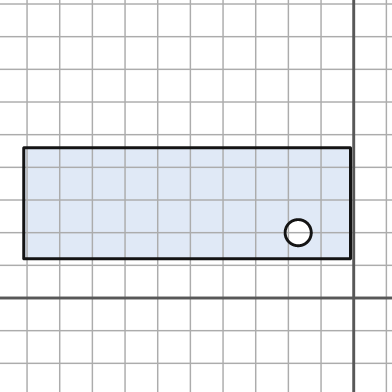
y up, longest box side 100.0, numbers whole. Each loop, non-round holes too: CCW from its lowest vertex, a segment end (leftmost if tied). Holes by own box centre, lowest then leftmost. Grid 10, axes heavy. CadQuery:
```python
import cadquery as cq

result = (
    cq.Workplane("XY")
    .moveTo(-101.0, 12.0)
    .lineTo(-1.0, 12.0)
    .lineTo(-1.0, 46.0)
    .lineTo(-101.0, 46.0)
    .close()
    .moveTo(-17.0, 20.0)
    .circle(4.0)
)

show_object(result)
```